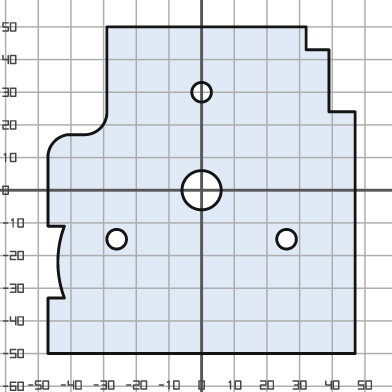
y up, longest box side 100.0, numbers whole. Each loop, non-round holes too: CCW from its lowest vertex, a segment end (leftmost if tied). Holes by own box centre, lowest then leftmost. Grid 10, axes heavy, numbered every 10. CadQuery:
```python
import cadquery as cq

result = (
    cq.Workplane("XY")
    .moveTo(-47.0, -50.0)
    .lineTo(47.0, -50.0)
    .lineTo(47.0, 24.0)
    .lineTo(39.0, 24.0)
    .lineTo(39.0, 43.0)
    .lineTo(32.0, 43.0)
    .lineTo(32.0, 50.0)
    .lineTo(-29.0, 50.0)
    .lineTo(-29.0, 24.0)
    .threePointArc((-31.0, 19.0), (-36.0, 17.0))
    .lineTo(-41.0, 17.0)
    .threePointArc((-45.0, 15.0), (-47.0, 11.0))
    .lineTo(-47.0, -11.0)
    .lineTo(-42.0, -11.0)
    .threePointArc((-44.0, -22.0), (-42.0, -33.0))
    .lineTo(-47.0, -33.0)
    .close()
    .moveTo(-26.0, -15.0)
    .circle(3.0)
    .moveTo(26.0, -15.0)
    .circle(3.0)
    .moveTo(0.0, 0.0)
    .circle(6.0)
    .moveTo(0.0, 30.0)
    .circle(3.0)
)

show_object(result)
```